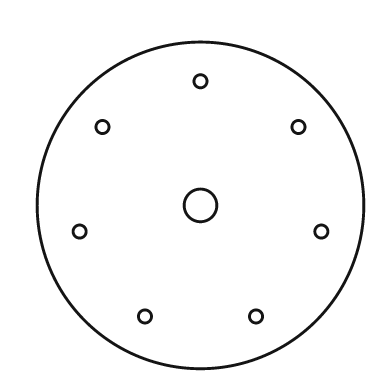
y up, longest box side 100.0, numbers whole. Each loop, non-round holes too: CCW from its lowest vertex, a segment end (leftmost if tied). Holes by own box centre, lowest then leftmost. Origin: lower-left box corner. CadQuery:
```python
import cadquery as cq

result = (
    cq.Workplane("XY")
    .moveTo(50.0, 50.0)
    .circle(50.0)
    .moveTo(33.0, 16.0)
    .circle(2.0)
    .moveTo(67.0, 16.0)
    .circle(2.0)
    .moveTo(13.0, 42.0)
    .circle(2.0)
    .moveTo(87.0, 42.0)
    .circle(2.0)
    .moveTo(50.0, 50.0)
    .circle(5.0)
    .moveTo(20.0, 74.0)
    .circle(2.0)
    .moveTo(80.0, 74.0)
    .circle(2.0)
    .moveTo(50.0, 88.0)
    .circle(2.0)
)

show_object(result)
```